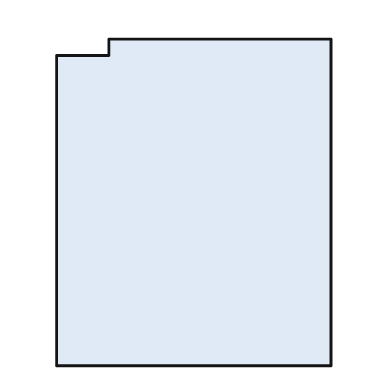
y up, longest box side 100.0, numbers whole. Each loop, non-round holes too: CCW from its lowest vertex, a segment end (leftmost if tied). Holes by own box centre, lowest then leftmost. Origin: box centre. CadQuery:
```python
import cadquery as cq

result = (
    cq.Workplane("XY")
    .moveTo(-42.0, -50.0)
    .lineTo(42.0, -50.0)
    .lineTo(42.0, 50.0)
    .lineTo(-26.0, 50.0)
    .lineTo(-26.0, 45.0)
    .lineTo(-42.0, 45.0)
    .close()
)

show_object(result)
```